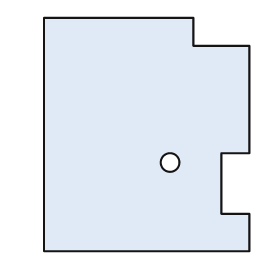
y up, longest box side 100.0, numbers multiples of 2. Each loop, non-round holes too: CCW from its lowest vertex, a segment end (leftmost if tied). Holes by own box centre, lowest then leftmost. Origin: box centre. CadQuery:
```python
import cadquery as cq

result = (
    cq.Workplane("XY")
    .moveTo(-44.0, -50.0)
    .lineTo(44.0, -50.0)
    .lineTo(44.0, -34.0)
    .lineTo(32.0, -34.0)
    .lineTo(32.0, -8.0)
    .lineTo(44.0, -8.0)
    .lineTo(44.0, 38.0)
    .lineTo(20.0, 38.0)
    .lineTo(20.0, 50.0)
    .lineTo(-44.0, 50.0)
    .close()
    .moveTo(10.0, -12.0)
    .circle(4.0)
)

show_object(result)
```